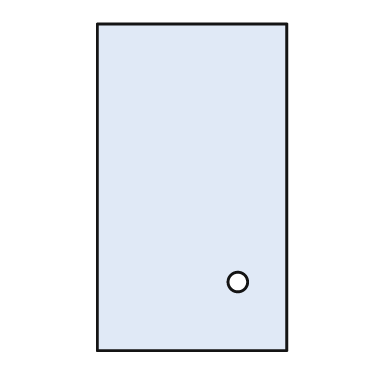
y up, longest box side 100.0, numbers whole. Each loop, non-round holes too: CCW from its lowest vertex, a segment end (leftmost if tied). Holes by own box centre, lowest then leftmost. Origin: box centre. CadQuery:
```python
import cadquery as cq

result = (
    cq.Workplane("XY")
    .moveTo(-29.0, -50.0)
    .lineTo(29.0, -50.0)
    .lineTo(29.0, 50.0)
    .lineTo(-29.0, 50.0)
    .close()
    .moveTo(14.0, -29.0)
    .circle(3.0)
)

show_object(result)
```